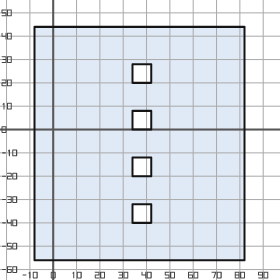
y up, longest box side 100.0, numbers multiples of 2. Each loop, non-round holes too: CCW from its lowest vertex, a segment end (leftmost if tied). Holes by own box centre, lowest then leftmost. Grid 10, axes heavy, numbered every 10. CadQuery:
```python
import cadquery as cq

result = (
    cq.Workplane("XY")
    .moveTo(-8.0, -56.0)
    .lineTo(82.0, -56.0)
    .lineTo(82.0, 44.0)
    .lineTo(-8.0, 44.0)
    .close()
    .moveTo(34.0, -40.0)
    .lineTo(42.0, -40.0)
    .lineTo(42.0, -32.0)
    .lineTo(34.0, -32.0)
    .close()
    .moveTo(34.0, -20.0)
    .lineTo(42.0, -20.0)
    .lineTo(42.0, -12.0)
    .lineTo(34.0, -12.0)
    .close()
    .moveTo(34.0, 0.0)
    .lineTo(42.0, 0.0)
    .lineTo(42.0, 8.0)
    .lineTo(34.0, 8.0)
    .close()
    .moveTo(34.0, 20.0)
    .lineTo(42.0, 20.0)
    .lineTo(42.0, 28.0)
    .lineTo(34.0, 28.0)
    .close()
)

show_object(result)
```